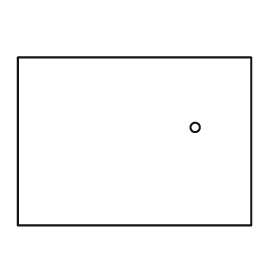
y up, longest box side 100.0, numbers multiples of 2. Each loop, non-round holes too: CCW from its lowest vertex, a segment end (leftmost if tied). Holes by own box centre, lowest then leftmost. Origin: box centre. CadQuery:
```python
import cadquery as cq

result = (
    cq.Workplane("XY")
    .moveTo(-50.0, -36.0)
    .lineTo(50.0, -36.0)
    .lineTo(50.0, 36.0)
    .lineTo(-50.0, 36.0)
    .close()
    .moveTo(26.0, 6.0)
    .circle(2.0)
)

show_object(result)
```